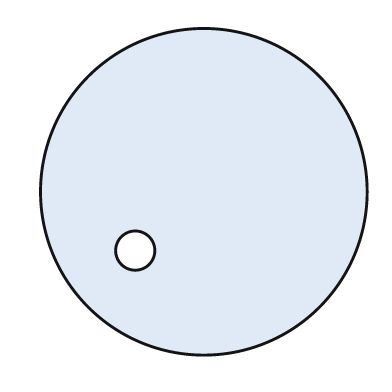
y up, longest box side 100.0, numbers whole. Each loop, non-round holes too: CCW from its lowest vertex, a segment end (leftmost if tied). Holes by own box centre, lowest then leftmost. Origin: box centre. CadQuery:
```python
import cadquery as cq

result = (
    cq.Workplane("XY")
    .moveTo(0.0, 0.0)
    .circle(50.0)
    .moveTo(-21.0, -18.0)
    .circle(6.0)
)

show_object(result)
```